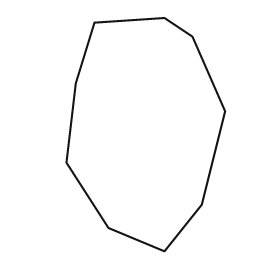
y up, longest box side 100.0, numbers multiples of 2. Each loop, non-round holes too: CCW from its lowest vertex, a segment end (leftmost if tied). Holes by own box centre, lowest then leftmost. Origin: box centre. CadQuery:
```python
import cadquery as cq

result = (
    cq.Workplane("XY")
    .moveTo(8.0, -50.0)
    .lineTo(24.0, -30.0)
    .lineTo(34.0, 10.0)
    .lineTo(20.0, 42.0)
    .lineTo(8.0, 50.0)
    .lineTo(-22.0, 48.0)
    .lineTo(-30.0, 22.0)
    .lineTo(-34.0, -12.0)
    .lineTo(-16.0, -40.0)
    .close()
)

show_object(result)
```